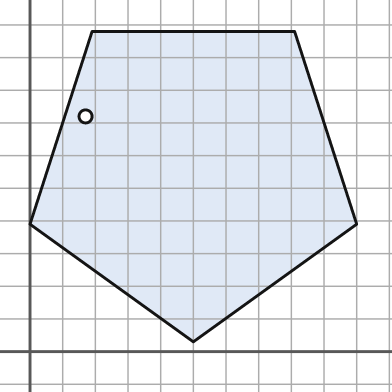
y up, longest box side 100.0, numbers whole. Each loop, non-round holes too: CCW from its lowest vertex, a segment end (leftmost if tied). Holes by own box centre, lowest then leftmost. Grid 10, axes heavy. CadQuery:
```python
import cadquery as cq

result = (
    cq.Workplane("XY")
    .moveTo(50.0, 3.0)
    .lineTo(100.0, 39.0)
    .lineTo(81.0, 98.0)
    .lineTo(19.0, 98.0)
    .lineTo(0.0, 39.0)
    .close()
    .moveTo(17.0, 72.0)
    .circle(2.0)
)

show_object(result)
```